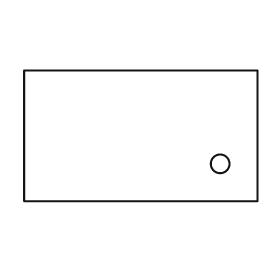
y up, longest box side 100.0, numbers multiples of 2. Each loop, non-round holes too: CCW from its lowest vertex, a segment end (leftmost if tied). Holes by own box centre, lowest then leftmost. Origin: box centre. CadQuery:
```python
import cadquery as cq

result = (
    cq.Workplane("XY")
    .moveTo(-50.0, -28.0)
    .lineTo(50.0, -28.0)
    .lineTo(50.0, 28.0)
    .lineTo(-50.0, 28.0)
    .close()
    .moveTo(34.0, -12.0)
    .circle(4.0)
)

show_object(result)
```